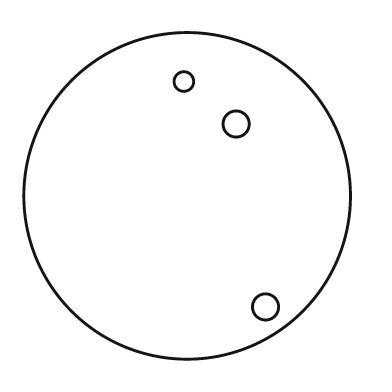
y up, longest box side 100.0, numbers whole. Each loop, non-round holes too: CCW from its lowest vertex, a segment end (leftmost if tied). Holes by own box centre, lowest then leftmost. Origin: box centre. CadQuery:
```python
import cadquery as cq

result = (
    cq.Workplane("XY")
    .moveTo(0.0, 0.0)
    .circle(50.0)
    .moveTo(24.0, -34.0)
    .circle(4.0)
    .moveTo(15.0, 22.0)
    .circle(4.0)
    .moveTo(-1.0, 35.0)
    .circle(3.0)
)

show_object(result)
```